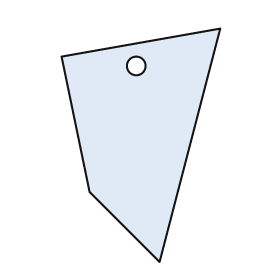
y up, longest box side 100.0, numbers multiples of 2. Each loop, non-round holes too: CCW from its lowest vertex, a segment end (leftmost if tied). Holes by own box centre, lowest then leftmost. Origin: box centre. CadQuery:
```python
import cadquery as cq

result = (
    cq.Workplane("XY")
    .moveTo(8.0, -50.0)
    .lineTo(34.0, 50.0)
    .lineTo(-34.0, 38.0)
    .lineTo(-22.0, -20.0)
    .close()
    .moveTo(-2.0, 34.0)
    .circle(4.0)
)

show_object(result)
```